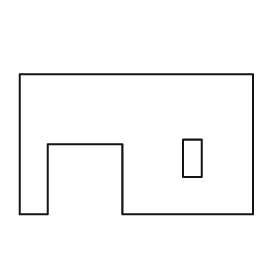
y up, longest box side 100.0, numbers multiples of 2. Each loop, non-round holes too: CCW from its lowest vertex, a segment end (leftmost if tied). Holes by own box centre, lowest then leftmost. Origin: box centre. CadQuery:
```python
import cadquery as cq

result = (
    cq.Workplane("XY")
    .moveTo(-50.0, -30.0)
    .lineTo(-38.0, -30.0)
    .lineTo(-38.0, 0.0)
    .lineTo(-6.0, 0.0)
    .lineTo(-6.0, -30.0)
    .lineTo(50.0, -30.0)
    .lineTo(50.0, 30.0)
    .lineTo(-50.0, 30.0)
    .close()
    .moveTo(20.0, -14.0)
    .lineTo(28.0, -14.0)
    .lineTo(28.0, 2.0)
    .lineTo(20.0, 2.0)
    .close()
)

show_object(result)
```